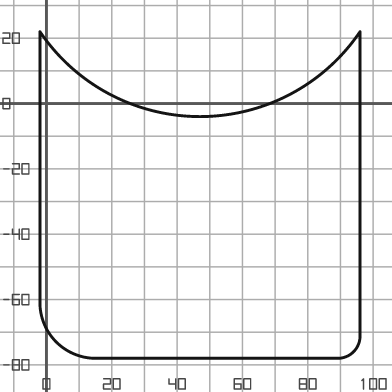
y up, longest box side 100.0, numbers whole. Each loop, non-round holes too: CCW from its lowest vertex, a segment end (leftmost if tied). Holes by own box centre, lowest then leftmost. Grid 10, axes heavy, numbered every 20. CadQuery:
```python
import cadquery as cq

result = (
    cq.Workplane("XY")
    .moveTo(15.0, -78.0)
    .lineTo(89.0, -78.0)
    .threePointArc((94.0, -76.0), (96.0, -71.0))
    .lineTo(96.0, 22.0)
    .threePointArc((47.0, -4.0), (-2.0, 22.0))
    .lineTo(-2.0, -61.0)
    .threePointArc((3.0, -73.0), (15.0, -78.0))
    .close()
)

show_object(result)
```